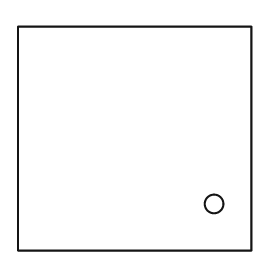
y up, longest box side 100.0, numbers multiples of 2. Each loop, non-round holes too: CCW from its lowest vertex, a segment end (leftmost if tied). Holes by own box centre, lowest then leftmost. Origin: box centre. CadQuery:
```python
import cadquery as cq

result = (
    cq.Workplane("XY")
    .moveTo(-50.0, -48.0)
    .lineTo(50.0, -48.0)
    .lineTo(50.0, 48.0)
    .lineTo(-50.0, 48.0)
    .close()
    .moveTo(34.0, -28.0)
    .circle(4.0)
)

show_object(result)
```